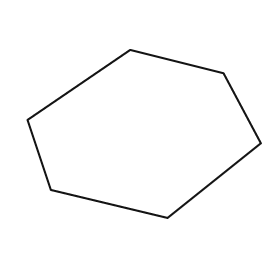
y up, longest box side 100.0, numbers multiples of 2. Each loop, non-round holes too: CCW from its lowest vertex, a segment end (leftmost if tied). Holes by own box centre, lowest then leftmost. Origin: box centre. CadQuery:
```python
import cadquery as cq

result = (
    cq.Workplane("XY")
    .moveTo(10.0, -36.0)
    .lineTo(50.0, -4.0)
    .lineTo(34.0, 26.0)
    .lineTo(-6.0, 36.0)
    .lineTo(-50.0, 6.0)
    .lineTo(-40.0, -24.0)
    .close()
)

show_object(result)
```